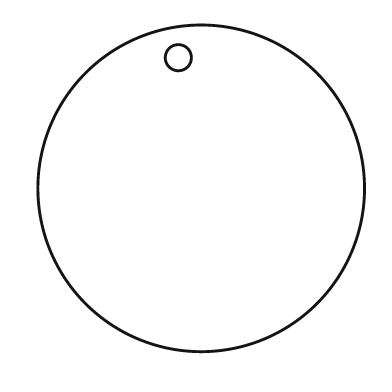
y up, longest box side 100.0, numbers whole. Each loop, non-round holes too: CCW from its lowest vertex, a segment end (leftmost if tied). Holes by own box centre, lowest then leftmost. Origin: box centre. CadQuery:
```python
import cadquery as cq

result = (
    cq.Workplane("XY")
    .moveTo(0.0, 0.0)
    .circle(50.0)
    .moveTo(-7.0, 40.0)
    .circle(4.0)
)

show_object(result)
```